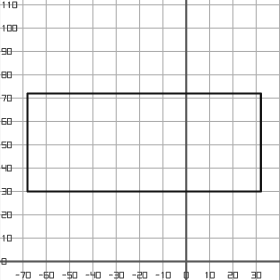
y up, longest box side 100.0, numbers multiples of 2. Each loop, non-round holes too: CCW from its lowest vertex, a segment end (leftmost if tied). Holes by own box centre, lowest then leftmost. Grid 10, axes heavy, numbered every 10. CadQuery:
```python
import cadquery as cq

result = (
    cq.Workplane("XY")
    .moveTo(-68.0, 30.0)
    .lineTo(32.0, 30.0)
    .lineTo(32.0, 72.0)
    .lineTo(-68.0, 72.0)
    .close()
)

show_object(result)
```